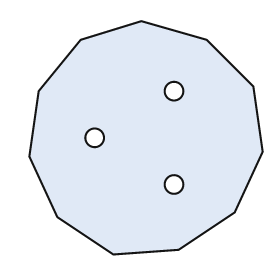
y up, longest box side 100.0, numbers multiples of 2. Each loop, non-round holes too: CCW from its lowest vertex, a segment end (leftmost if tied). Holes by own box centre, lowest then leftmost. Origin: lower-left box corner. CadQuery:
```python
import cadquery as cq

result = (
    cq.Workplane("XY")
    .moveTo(36.0, 0.0)
    .lineTo(64.0, 2.0)
    .lineTo(88.0, 18.0)
    .lineTo(100.0, 44.0)
    .lineTo(96.0, 72.0)
    .lineTo(76.0, 92.0)
    .lineTo(48.0, 100.0)
    .lineTo(22.0, 92.0)
    .lineTo(4.0, 70.0)
    .lineTo(0.0, 42.0)
    .lineTo(12.0, 16.0)
    .close()
    .moveTo(62.0, 30.0)
    .circle(4.0)
    .moveTo(28.0, 50.0)
    .circle(4.0)
    .moveTo(62.0, 70.0)
    .circle(4.0)
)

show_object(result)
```